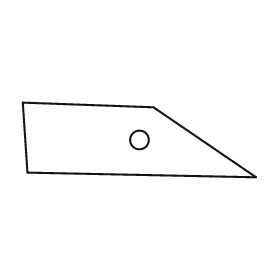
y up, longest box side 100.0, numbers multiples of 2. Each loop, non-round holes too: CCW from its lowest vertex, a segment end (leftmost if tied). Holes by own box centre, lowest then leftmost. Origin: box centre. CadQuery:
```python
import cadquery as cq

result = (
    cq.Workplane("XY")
    .moveTo(50.0, -16.0)
    .lineTo(6.0, 14.0)
    .lineTo(-50.0, 16.0)
    .lineTo(-48.0, -14.0)
    .close()
    .moveTo(0.0, 0.0)
    .circle(4.0)
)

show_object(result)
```